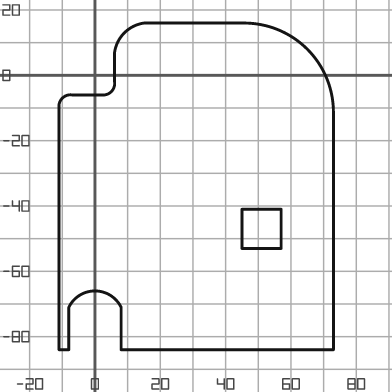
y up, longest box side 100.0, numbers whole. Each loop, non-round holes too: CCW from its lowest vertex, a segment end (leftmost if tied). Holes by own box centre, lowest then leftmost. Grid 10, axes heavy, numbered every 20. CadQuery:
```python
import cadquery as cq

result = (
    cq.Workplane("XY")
    .moveTo(-11.0, -84.0)
    .lineTo(-8.0, -84.0)
    .lineTo(-8.0, -71.0)
    .threePointArc((0.0, -66.0), (8.0, -71.0))
    .lineTo(8.0, -84.0)
    .lineTo(73.0, -84.0)
    .lineTo(73.0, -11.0)
    .threePointArc((65.0, 8.0), (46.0, 16.0))
    .lineTo(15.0, 16.0)
    .threePointArc((9.0, 13.0), (6.0, 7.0))
    .lineTo(6.0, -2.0)
    .threePointArc((5.0, -5.0), (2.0, -6.0))
    .lineTo(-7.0, -6.0)
    .threePointArc((-10.0, -7.0), (-11.0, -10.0))
    .close()
    .moveTo(45.0, -53.0)
    .lineTo(57.0, -53.0)
    .lineTo(57.0, -41.0)
    .lineTo(45.0, -41.0)
    .close()
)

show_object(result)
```